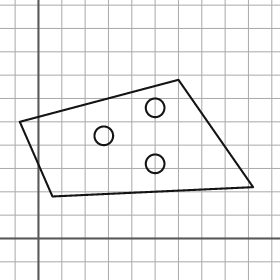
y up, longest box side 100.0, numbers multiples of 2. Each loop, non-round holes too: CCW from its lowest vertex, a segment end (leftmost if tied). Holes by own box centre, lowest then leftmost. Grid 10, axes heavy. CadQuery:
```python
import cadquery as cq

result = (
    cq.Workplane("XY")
    .moveTo(6.0, 18.0)
    .lineTo(92.0, 22.0)
    .lineTo(60.0, 68.0)
    .lineTo(-8.0, 50.0)
    .close()
    .moveTo(50.0, 32.0)
    .circle(4.0)
    .moveTo(28.0, 44.0)
    .circle(4.0)
    .moveTo(50.0, 56.0)
    .circle(4.0)
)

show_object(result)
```